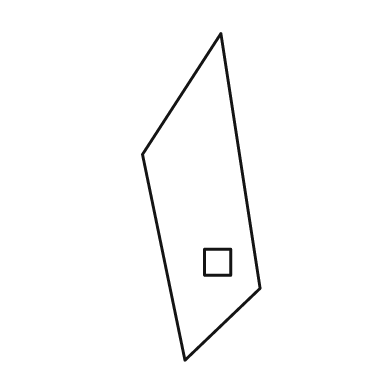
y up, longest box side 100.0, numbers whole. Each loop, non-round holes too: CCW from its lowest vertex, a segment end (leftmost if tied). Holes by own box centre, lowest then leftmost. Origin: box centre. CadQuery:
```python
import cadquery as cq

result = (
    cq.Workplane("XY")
    .moveTo(-5.0, -50.0)
    .lineTo(18.0, -28.0)
    .lineTo(6.0, 50.0)
    .lineTo(-18.0, 13.0)
    .close()
    .moveTo(1.0, -24.0)
    .lineTo(9.0, -24.0)
    .lineTo(9.0, -16.0)
    .lineTo(1.0, -16.0)
    .close()
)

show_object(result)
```